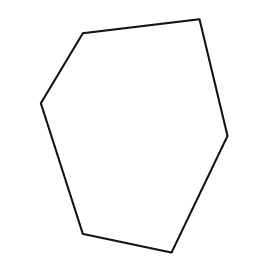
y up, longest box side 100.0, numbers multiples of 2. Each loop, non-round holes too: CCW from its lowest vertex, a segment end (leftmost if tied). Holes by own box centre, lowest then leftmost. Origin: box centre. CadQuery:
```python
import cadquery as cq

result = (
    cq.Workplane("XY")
    .moveTo(16.0, -50.0)
    .lineTo(40.0, 0.0)
    .lineTo(28.0, 50.0)
    .lineTo(-22.0, 44.0)
    .lineTo(-40.0, 14.0)
    .lineTo(-22.0, -42.0)
    .close()
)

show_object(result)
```